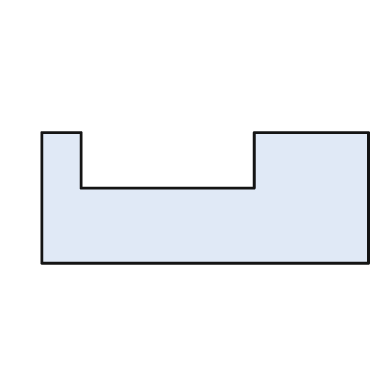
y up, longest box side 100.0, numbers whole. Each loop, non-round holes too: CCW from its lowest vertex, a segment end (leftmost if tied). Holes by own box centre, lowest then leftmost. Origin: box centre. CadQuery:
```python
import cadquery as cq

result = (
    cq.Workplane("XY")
    .moveTo(-50.0, -20.0)
    .lineTo(50.0, -20.0)
    .lineTo(50.0, 20.0)
    .lineTo(15.0, 20.0)
    .lineTo(15.0, 3.0)
    .lineTo(-38.0, 3.0)
    .lineTo(-38.0, 20.0)
    .lineTo(-50.0, 20.0)
    .close()
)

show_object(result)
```